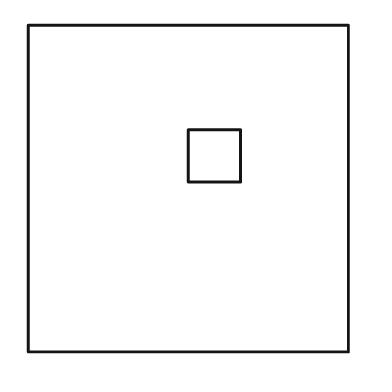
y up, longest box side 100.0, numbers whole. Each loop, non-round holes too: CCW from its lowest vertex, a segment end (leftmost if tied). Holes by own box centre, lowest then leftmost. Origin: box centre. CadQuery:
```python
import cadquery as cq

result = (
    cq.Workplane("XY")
    .moveTo(-49.0, -50.0)
    .lineTo(49.0, -50.0)
    .lineTo(49.0, 50.0)
    .lineTo(-49.0, 50.0)
    .close()
    .moveTo(0.0, 2.0)
    .lineTo(16.0, 2.0)
    .lineTo(16.0, 18.0)
    .lineTo(0.0, 18.0)
    .close()
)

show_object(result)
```